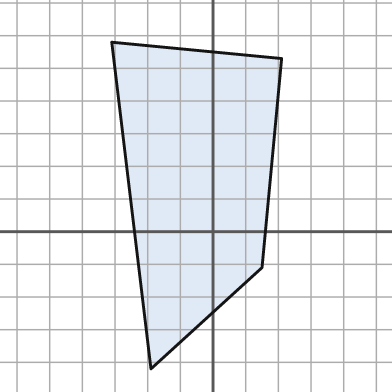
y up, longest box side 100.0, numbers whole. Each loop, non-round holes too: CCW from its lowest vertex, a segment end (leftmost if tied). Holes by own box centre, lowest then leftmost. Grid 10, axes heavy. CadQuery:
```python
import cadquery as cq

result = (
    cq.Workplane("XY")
    .moveTo(-19.0, -42.0)
    .lineTo(15.0, -11.0)
    .lineTo(21.0, 53.0)
    .lineTo(-31.0, 58.0)
    .close()
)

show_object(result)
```